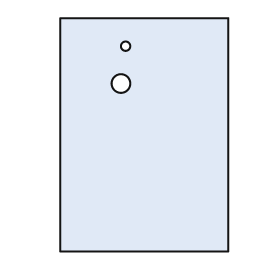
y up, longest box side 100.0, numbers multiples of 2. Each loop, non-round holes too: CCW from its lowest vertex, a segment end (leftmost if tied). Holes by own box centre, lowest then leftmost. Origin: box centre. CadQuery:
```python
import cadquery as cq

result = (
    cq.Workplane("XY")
    .moveTo(-36.0, -50.0)
    .lineTo(36.0, -50.0)
    .lineTo(36.0, 50.0)
    .lineTo(-36.0, 50.0)
    .close()
    .moveTo(-10.0, 22.0)
    .circle(4.0)
    .moveTo(-8.0, 38.0)
    .circle(2.0)
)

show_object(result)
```